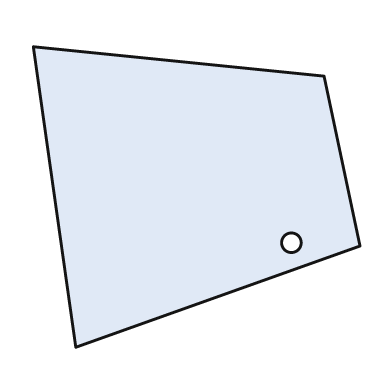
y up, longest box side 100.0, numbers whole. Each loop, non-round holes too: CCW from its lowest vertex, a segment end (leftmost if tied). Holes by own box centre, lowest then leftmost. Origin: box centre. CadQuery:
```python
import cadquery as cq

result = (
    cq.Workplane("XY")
    .moveTo(-37.0, -46.0)
    .lineTo(50.0, -15.0)
    .lineTo(39.0, 37.0)
    .lineTo(-50.0, 46.0)
    .close()
    .moveTo(29.0, -14.0)
    .circle(3.0)
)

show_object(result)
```